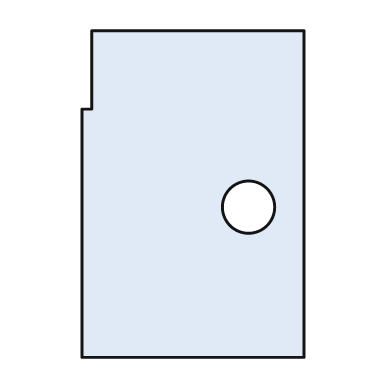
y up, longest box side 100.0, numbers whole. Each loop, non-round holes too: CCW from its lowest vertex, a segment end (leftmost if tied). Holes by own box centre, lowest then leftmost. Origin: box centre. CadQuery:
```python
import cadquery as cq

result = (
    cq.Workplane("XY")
    .moveTo(-34.0, -50.0)
    .lineTo(34.0, -50.0)
    .lineTo(34.0, 50.0)
    .lineTo(-31.0, 50.0)
    .lineTo(-31.0, 26.0)
    .lineTo(-34.0, 26.0)
    .close()
    .moveTo(17.0, -4.0)
    .circle(8.0)
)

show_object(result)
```